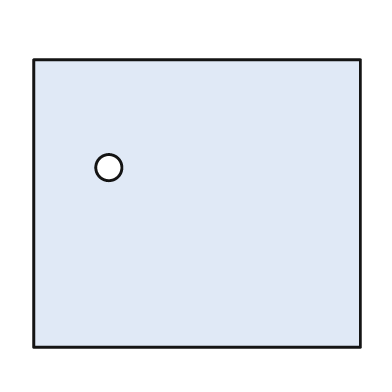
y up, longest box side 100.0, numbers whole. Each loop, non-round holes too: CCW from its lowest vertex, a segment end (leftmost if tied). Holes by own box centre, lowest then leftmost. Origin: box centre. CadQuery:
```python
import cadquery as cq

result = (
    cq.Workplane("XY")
    .moveTo(-50.0, -44.0)
    .lineTo(50.0, -44.0)
    .lineTo(50.0, 44.0)
    .lineTo(-50.0, 44.0)
    .close()
    .moveTo(-27.0, 11.0)
    .circle(4.0)
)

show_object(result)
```